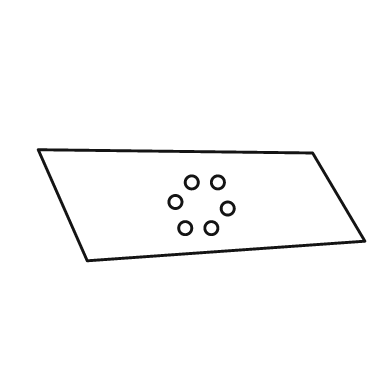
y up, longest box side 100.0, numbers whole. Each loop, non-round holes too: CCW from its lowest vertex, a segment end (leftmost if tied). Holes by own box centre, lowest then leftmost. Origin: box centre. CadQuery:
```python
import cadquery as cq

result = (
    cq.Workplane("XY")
    .moveTo(-35.0, -17.0)
    .lineTo(50.0, -11.0)
    .lineTo(34.0, 16.0)
    .lineTo(-50.0, 17.0)
    .close()
    .moveTo(-5.0, -7.0)
    .circle(2.0)
    .moveTo(3.0, -7.0)
    .circle(2.0)
    .moveTo(8.0, -1.0)
    .circle(2.0)
    .moveTo(-8.0, 1.0)
    .circle(2.0)
    .moveTo(-3.0, 7.0)
    .circle(2.0)
    .moveTo(5.0, 7.0)
    .circle(2.0)
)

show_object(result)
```